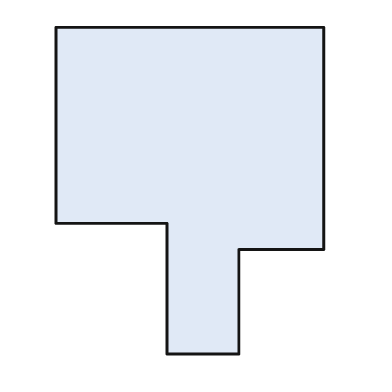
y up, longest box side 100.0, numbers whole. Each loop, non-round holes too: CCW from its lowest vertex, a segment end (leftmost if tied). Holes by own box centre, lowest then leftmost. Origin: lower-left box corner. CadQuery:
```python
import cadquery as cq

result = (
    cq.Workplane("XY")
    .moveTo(34.0, 0.0)
    .lineTo(56.0, 0.0)
    .lineTo(56.0, 32.0)
    .lineTo(82.0, 32.0)
    .lineTo(82.0, 100.0)
    .lineTo(0.0, 100.0)
    .lineTo(0.0, 40.0)
    .lineTo(34.0, 40.0)
    .close()
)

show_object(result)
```